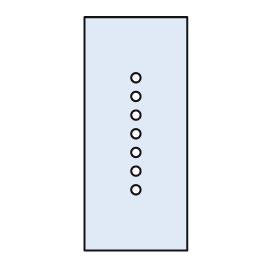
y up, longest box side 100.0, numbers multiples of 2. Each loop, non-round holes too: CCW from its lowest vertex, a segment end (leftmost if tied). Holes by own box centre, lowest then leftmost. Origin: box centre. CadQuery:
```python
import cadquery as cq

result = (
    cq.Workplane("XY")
    .moveTo(-22.0, -50.0)
    .lineTo(22.0, -50.0)
    .lineTo(22.0, 50.0)
    .lineTo(-22.0, 50.0)
    .close()
    .moveTo(0.0, -24.0)
    .circle(2.0)
    .moveTo(0.0, -16.0)
    .circle(2.0)
    .moveTo(0.0, -8.0)
    .circle(2.0)
    .moveTo(0.0, 0.0)
    .circle(2.0)
    .moveTo(0.0, 8.0)
    .circle(2.0)
    .moveTo(0.0, 16.0)
    .circle(2.0)
    .moveTo(0.0, 24.0)
    .circle(2.0)
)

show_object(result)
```